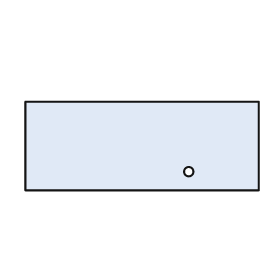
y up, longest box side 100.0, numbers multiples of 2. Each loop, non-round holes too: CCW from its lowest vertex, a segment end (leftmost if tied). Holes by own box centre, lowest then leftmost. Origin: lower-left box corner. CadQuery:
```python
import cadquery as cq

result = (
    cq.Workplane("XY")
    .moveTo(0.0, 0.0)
    .lineTo(100.0, 0.0)
    .lineTo(100.0, 38.0)
    .lineTo(0.0, 38.0)
    .close()
    .moveTo(70.0, 8.0)
    .circle(2.0)
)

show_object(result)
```